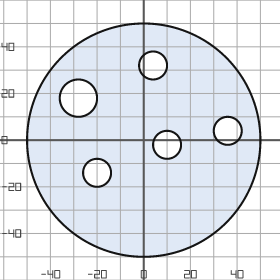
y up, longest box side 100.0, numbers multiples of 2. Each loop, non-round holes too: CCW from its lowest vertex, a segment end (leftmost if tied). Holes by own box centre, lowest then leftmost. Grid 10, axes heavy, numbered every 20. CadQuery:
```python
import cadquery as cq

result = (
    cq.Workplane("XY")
    .moveTo(0.0, 0.0)
    .circle(50.0)
    .moveTo(-20.0, -14.0)
    .circle(6.0)
    .moveTo(10.0, -2.0)
    .circle(6.0)
    .moveTo(36.0, 4.0)
    .circle(6.0)
    .moveTo(-28.0, 18.0)
    .circle(8.0)
    .moveTo(4.0, 32.0)
    .circle(6.0)
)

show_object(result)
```